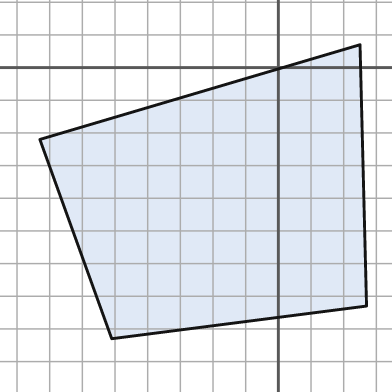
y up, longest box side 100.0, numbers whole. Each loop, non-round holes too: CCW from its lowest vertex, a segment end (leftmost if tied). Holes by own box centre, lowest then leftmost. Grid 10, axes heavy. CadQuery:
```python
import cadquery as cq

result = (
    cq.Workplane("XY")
    .moveTo(-51.0, -83.0)
    .lineTo(27.0, -73.0)
    .lineTo(25.0, 7.0)
    .lineTo(-73.0, -22.0)
    .close()
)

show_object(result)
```